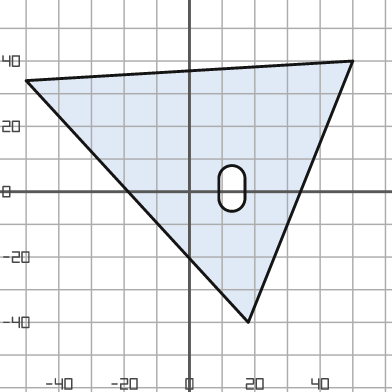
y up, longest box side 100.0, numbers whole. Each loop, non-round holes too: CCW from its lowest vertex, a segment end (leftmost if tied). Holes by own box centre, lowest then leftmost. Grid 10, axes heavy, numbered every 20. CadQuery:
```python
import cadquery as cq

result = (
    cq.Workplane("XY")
    .moveTo(18.0, -40.0)
    .lineTo(50.0, 40.0)
    .lineTo(-50.0, 34.0)
    .close()
    .moveTo(9.0, -2.0)
    .threePointArc((13.0, -6.0), (17.0, -2.0))
    .lineTo(17.0, 4.0)
    .threePointArc((13.0, 8.0), (9.0, 4.0))
    .close()
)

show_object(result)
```